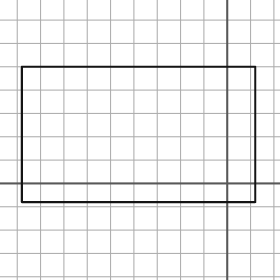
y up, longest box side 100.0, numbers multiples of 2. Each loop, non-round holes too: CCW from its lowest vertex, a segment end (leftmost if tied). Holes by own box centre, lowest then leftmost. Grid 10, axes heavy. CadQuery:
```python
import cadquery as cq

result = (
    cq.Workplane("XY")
    .moveTo(-88.0, -8.0)
    .lineTo(12.0, -8.0)
    .lineTo(12.0, 50.0)
    .lineTo(-88.0, 50.0)
    .close()
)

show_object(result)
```